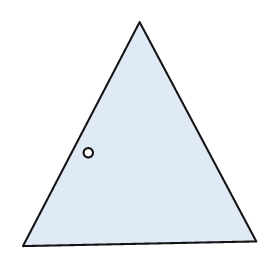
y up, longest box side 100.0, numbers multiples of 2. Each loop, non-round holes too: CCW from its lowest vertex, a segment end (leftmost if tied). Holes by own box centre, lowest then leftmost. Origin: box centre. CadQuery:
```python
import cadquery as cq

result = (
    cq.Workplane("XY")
    .moveTo(-50.0, -48.0)
    .lineTo(50.0, -46.0)
    .lineTo(0.0, 48.0)
    .close()
    .moveTo(-22.0, -8.0)
    .circle(2.0)
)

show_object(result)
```